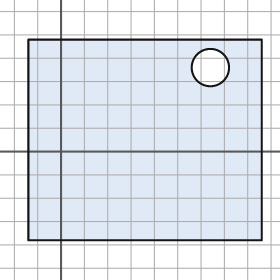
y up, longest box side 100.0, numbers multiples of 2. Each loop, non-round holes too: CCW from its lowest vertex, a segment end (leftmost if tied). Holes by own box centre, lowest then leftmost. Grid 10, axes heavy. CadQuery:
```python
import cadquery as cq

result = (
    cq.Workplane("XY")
    .moveTo(-14.0, -38.0)
    .lineTo(86.0, -38.0)
    .lineTo(86.0, 48.0)
    .lineTo(-14.0, 48.0)
    .close()
    .moveTo(64.0, 36.0)
    .circle(8.0)
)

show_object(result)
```